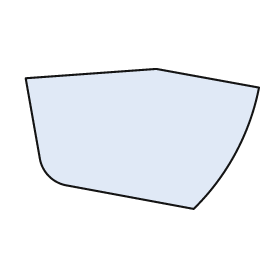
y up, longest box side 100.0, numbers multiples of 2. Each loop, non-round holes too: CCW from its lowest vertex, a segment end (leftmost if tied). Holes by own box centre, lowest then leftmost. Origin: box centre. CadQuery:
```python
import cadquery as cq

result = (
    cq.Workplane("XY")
    .moveTo(22.0, -30.0)
    .threePointArc((40.0, -6.0), (50.0, 22.0))
    .lineTo(6.0, 30.0)
    .lineTo(-50.0, 26.0)
    .lineTo(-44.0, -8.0)
    .threePointArc((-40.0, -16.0), (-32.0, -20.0))
    .close()
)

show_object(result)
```